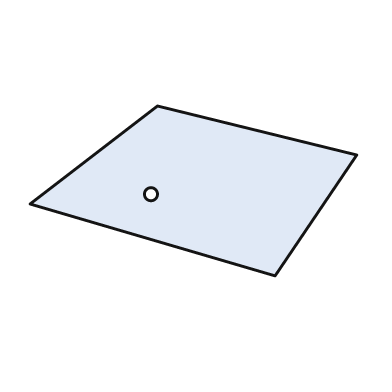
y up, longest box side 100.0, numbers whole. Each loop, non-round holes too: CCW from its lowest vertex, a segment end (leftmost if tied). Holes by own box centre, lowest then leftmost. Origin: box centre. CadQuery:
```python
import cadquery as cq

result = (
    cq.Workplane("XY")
    .moveTo(25.0, -26.0)
    .lineTo(50.0, 11.0)
    .lineTo(-11.0, 26.0)
    .lineTo(-50.0, -4.0)
    .close()
    .moveTo(-13.0, -1.0)
    .circle(2.0)
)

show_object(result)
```